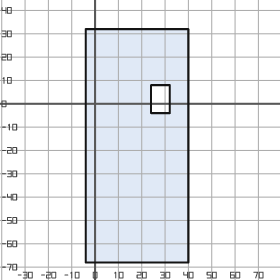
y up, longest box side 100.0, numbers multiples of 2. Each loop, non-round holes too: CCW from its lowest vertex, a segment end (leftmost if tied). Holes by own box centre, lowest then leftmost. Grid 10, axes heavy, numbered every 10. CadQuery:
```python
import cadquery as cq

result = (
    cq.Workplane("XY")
    .moveTo(-4.0, -68.0)
    .lineTo(40.0, -68.0)
    .lineTo(40.0, 32.0)
    .lineTo(-4.0, 32.0)
    .close()
    .moveTo(24.0, -4.0)
    .lineTo(32.0, -4.0)
    .lineTo(32.0, 8.0)
    .lineTo(24.0, 8.0)
    .close()
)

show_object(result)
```